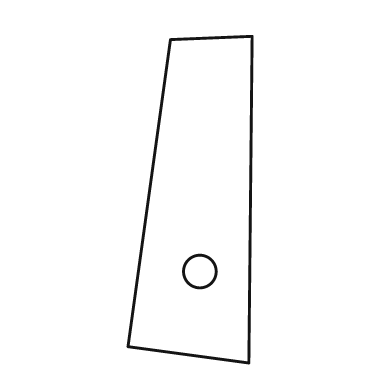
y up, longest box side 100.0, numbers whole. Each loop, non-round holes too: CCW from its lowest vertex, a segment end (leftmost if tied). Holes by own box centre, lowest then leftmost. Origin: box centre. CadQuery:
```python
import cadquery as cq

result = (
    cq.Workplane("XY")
    .moveTo(18.0, -50.0)
    .lineTo(19.0, 50.0)
    .lineTo(-6.0, 49.0)
    .lineTo(-19.0, -45.0)
    .close()
    .moveTo(3.0, -22.0)
    .circle(5.0)
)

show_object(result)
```